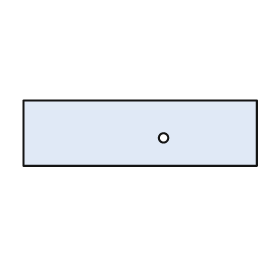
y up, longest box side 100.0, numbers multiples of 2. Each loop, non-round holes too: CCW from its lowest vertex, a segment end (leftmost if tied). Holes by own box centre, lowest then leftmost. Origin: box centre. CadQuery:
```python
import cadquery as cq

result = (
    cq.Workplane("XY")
    .moveTo(-50.0, -14.0)
    .lineTo(50.0, -14.0)
    .lineTo(50.0, 14.0)
    .lineTo(-50.0, 14.0)
    .close()
    .moveTo(10.0, -2.0)
    .circle(2.0)
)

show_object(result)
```